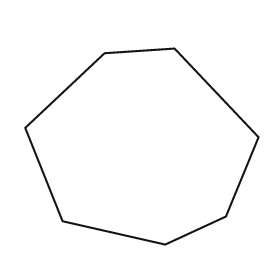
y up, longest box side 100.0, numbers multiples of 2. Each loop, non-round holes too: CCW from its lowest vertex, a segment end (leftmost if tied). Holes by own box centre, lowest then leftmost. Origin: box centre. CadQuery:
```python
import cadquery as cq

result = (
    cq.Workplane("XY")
    .moveTo(10.0, -42.0)
    .lineTo(36.0, -30.0)
    .lineTo(50.0, 4.0)
    .lineTo(14.0, 42.0)
    .lineTo(-16.0, 40.0)
    .lineTo(-50.0, 8.0)
    .lineTo(-34.0, -32.0)
    .close()
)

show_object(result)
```